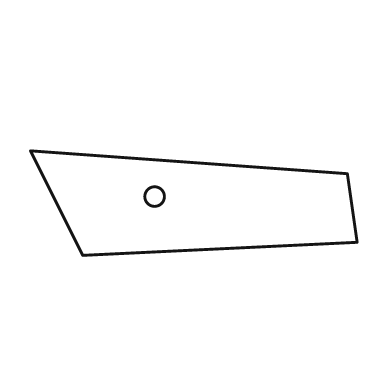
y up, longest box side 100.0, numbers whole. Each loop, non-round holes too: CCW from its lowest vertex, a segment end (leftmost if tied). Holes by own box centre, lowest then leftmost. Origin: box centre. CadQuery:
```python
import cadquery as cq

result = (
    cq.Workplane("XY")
    .moveTo(-34.0, -16.0)
    .lineTo(50.0, -12.0)
    .lineTo(47.0, 9.0)
    .lineTo(-50.0, 16.0)
    .close()
    .moveTo(-12.0, 2.0)
    .circle(3.0)
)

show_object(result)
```